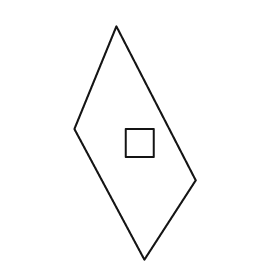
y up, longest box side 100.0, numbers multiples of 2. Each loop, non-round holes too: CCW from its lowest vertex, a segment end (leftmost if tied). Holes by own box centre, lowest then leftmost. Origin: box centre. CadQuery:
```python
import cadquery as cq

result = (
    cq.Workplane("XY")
    .moveTo(4.0, -50.0)
    .lineTo(26.0, -16.0)
    .lineTo(-8.0, 50.0)
    .lineTo(-26.0, 6.0)
    .close()
    .moveTo(-4.0, -6.0)
    .lineTo(8.0, -6.0)
    .lineTo(8.0, 6.0)
    .lineTo(-4.0, 6.0)
    .close()
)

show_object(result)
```